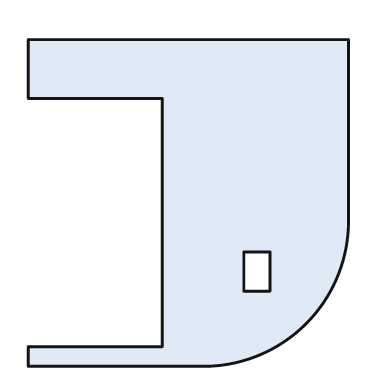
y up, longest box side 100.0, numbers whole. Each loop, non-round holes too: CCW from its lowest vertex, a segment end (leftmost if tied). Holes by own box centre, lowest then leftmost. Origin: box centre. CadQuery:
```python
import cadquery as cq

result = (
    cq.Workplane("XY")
    .moveTo(-49.0, -50.0)
    .lineTo(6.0, -50.0)
    .threePointArc((36.0, -37.0), (49.0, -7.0))
    .lineTo(49.0, 50.0)
    .lineTo(-49.0, 50.0)
    .lineTo(-49.0, 32.0)
    .lineTo(-8.0, 32.0)
    .lineTo(-8.0, -44.0)
    .lineTo(-49.0, -44.0)
    .close()
    .moveTo(17.0, -27.0)
    .lineTo(25.0, -27.0)
    .lineTo(25.0, -15.0)
    .lineTo(17.0, -15.0)
    .close()
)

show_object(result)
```